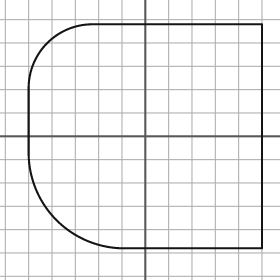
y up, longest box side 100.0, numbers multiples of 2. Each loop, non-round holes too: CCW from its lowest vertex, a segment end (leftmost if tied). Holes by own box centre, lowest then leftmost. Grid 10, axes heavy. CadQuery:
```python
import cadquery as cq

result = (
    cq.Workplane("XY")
    .moveTo(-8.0, -48.0)
    .lineTo(50.0, -48.0)
    .lineTo(50.0, 48.0)
    .lineTo(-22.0, 48.0)
    .threePointArc((-42.0, 40.0), (-50.0, 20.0))
    .lineTo(-50.0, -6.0)
    .threePointArc((-38.0, -36.0), (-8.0, -48.0))
    .close()
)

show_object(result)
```